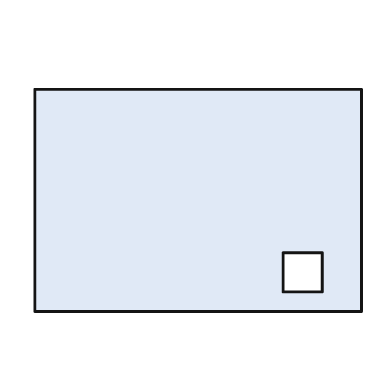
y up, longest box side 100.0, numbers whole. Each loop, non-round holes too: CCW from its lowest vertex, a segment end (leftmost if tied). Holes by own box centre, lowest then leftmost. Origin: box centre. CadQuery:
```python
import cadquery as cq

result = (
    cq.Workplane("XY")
    .moveTo(-50.0, -34.0)
    .lineTo(50.0, -34.0)
    .lineTo(50.0, 34.0)
    .lineTo(-50.0, 34.0)
    .close()
    .moveTo(26.0, -28.0)
    .lineTo(38.0, -28.0)
    .lineTo(38.0, -16.0)
    .lineTo(26.0, -16.0)
    .close()
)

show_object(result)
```